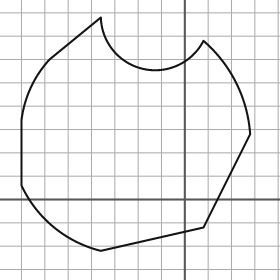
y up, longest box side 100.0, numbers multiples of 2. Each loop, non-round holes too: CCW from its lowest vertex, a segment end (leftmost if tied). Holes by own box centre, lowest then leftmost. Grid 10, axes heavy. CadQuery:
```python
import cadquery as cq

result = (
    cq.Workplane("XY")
    .moveTo(-36.0, -22.0)
    .lineTo(8.0, -12.0)
    .lineTo(28.0, 28.0)
    .threePointArc((22.0, 50.0), (8.0, 68.0))
    .threePointArc((-18.0, 56.0), (-36.0, 78.0))
    .lineTo(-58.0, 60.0)
    .threePointArc((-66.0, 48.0), (-70.0, 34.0))
    .lineTo(-70.0, 6.0)
    .threePointArc((-56.0, -12.0), (-36.0, -22.0))
    .close()
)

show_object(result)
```